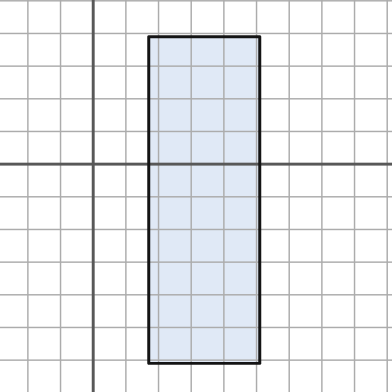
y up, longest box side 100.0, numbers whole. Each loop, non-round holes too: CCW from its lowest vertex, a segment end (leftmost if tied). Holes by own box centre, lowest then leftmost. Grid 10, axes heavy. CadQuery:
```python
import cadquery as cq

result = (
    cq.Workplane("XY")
    .moveTo(17.0, -61.0)
    .lineTo(51.0, -61.0)
    .lineTo(51.0, 39.0)
    .lineTo(17.0, 39.0)
    .close()
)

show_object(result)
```